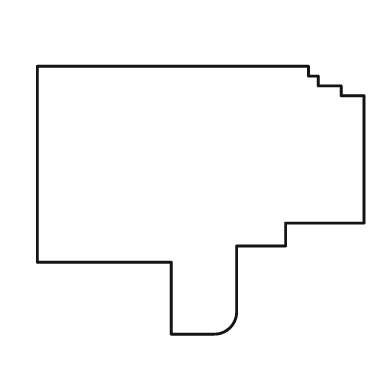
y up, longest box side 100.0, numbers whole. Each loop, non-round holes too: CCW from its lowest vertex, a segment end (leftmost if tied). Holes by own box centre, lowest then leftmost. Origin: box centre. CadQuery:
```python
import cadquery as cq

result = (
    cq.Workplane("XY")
    .moveTo(-9.0, -41.0)
    .lineTo(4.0, -41.0)
    .threePointArc((9.0, -39.0), (11.0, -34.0))
    .lineTo(11.0, -14.0)
    .lineTo(26.0, -14.0)
    .lineTo(26.0, -7.0)
    .lineTo(50.0, -7.0)
    .lineTo(50.0, 32.0)
    .lineTo(43.0, 32.0)
    .lineTo(43.0, 35.0)
    .lineTo(36.0, 35.0)
    .lineTo(36.0, 38.0)
    .lineTo(33.0, 38.0)
    .lineTo(33.0, 41.0)
    .lineTo(-50.0, 41.0)
    .lineTo(-50.0, -19.0)
    .lineTo(-9.0, -19.0)
    .close()
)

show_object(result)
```